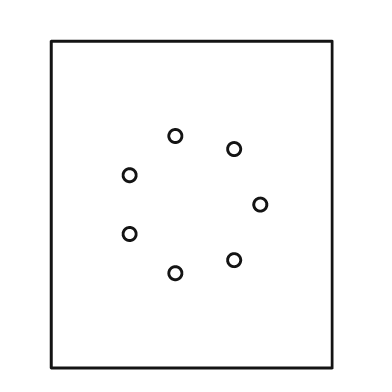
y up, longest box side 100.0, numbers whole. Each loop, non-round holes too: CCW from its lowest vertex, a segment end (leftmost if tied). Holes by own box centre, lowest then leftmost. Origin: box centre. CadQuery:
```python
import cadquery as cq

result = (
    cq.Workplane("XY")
    .moveTo(-43.0, -50.0)
    .lineTo(43.0, -50.0)
    .lineTo(43.0, 50.0)
    .lineTo(-43.0, 50.0)
    .close()
    .moveTo(-5.0, -21.0)
    .circle(2.0)
    .moveTo(13.0, -17.0)
    .circle(2.0)
    .moveTo(-19.0, -9.0)
    .circle(2.0)
    .moveTo(21.0, 0.0)
    .circle(2.0)
    .moveTo(-19.0, 9.0)
    .circle(2.0)
    .moveTo(13.0, 17.0)
    .circle(2.0)
    .moveTo(-5.0, 21.0)
    .circle(2.0)
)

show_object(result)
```